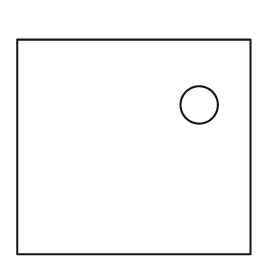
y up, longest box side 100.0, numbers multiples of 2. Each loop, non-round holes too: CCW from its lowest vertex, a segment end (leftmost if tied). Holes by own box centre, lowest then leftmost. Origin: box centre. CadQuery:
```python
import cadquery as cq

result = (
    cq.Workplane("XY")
    .moveTo(-50.0, -46.0)
    .lineTo(50.0, -46.0)
    .lineTo(50.0, 46.0)
    .lineTo(-50.0, 46.0)
    .close()
    .moveTo(28.0, 18.0)
    .circle(8.0)
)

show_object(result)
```